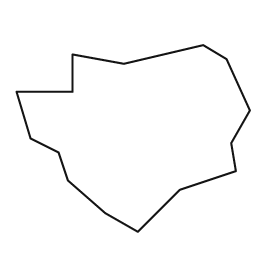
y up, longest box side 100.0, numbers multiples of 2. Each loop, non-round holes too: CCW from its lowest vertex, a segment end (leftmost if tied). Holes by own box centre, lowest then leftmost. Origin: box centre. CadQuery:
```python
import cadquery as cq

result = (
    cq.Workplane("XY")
    .moveTo(2.0, -40.0)
    .lineTo(20.0, -22.0)
    .lineTo(44.0, -14.0)
    .lineTo(42.0, -2.0)
    .lineTo(50.0, 12.0)
    .lineTo(40.0, 34.0)
    .lineTo(30.0, 40.0)
    .lineTo(-4.0, 32.0)
    .lineTo(-26.0, 36.0)
    .lineTo(-26.0, 20.0)
    .lineTo(-50.0, 20.0)
    .lineTo(-44.0, 0.0)
    .lineTo(-32.0, -6.0)
    .lineTo(-28.0, -18.0)
    .lineTo(-12.0, -32.0)
    .close()
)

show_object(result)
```